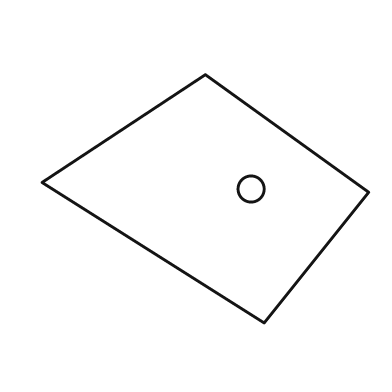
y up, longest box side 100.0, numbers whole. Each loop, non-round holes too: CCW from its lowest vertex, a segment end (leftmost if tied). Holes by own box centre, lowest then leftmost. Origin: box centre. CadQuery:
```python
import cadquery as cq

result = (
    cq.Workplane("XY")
    .moveTo(18.0, -38.0)
    .lineTo(50.0, 2.0)
    .lineTo(0.0, 38.0)
    .lineTo(-50.0, 5.0)
    .close()
    .moveTo(14.0, 3.0)
    .circle(4.0)
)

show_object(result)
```